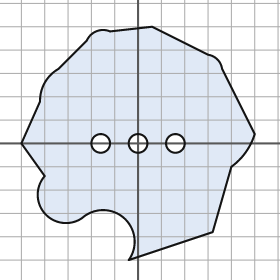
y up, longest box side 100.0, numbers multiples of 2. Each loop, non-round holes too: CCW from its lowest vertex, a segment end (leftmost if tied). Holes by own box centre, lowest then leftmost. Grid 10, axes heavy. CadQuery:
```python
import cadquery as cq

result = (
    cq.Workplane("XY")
    .moveTo(-4.0, -50.0)
    .lineTo(32.0, -38.0)
    .lineTo(40.0, -10.0)
    .threePointArc((46.0, -4.0), (50.0, 4.0))
    .lineTo(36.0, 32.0)
    .threePointArc((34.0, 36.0), (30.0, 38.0))
    .lineTo(6.0, 50.0)
    .lineTo(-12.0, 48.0)
    .threePointArc((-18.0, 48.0), (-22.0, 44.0))
    .lineTo(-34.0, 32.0)
    .threePointArc((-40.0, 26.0), (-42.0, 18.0))
    .lineTo(-50.0, 0.0)
    .lineTo(-40.0, -14.0)
    .threePointArc((-40.0, -30.0), (-24.0, -32.0))
    .threePointArc((-6.0, -32.0), (-4.0, -50.0))
    .close()
    .moveTo(-16.0, 0.0)
    .circle(4.0)
    .moveTo(0.0, 0.0)
    .circle(4.0)
    .moveTo(16.0, 0.0)
    .circle(4.0)
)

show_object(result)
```